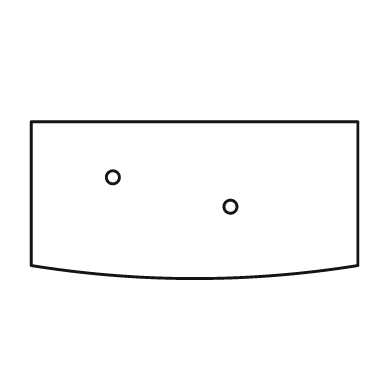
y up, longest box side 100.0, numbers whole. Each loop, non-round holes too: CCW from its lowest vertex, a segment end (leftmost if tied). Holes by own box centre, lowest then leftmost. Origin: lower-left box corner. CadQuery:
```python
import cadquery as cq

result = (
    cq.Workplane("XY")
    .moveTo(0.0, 4.0)
    .threePointArc((50.0, 0.0), (100.0, 4.0))
    .lineTo(100.0, 48.0)
    .lineTo(0.0, 48.0)
    .close()
    .moveTo(61.0, 22.0)
    .circle(2.0)
    .moveTo(25.0, 31.0)
    .circle(2.0)
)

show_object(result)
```